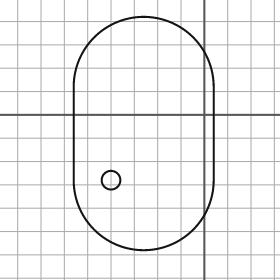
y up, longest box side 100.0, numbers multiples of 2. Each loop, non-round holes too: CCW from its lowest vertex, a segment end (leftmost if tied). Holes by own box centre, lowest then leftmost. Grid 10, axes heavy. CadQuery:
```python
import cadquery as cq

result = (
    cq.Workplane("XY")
    .moveTo(-56.0, -28.0)
    .threePointArc((-26.0, -58.0), (4.0, -28.0))
    .lineTo(4.0, 12.0)
    .threePointArc((-26.0, 42.0), (-56.0, 12.0))
    .close()
    .moveTo(-40.0, -28.0)
    .circle(4.0)
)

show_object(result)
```